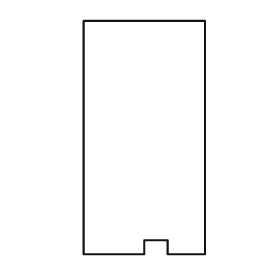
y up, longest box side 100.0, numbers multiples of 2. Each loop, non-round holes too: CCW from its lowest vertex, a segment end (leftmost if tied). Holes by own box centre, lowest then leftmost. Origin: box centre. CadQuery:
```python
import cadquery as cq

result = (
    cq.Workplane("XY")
    .moveTo(-26.0, -50.0)
    .lineTo(0.0, -50.0)
    .lineTo(0.0, -44.0)
    .lineTo(10.0, -44.0)
    .lineTo(10.0, -50.0)
    .lineTo(26.0, -50.0)
    .lineTo(26.0, 50.0)
    .lineTo(-26.0, 50.0)
    .close()
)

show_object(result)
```